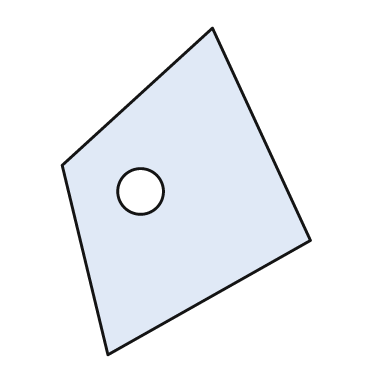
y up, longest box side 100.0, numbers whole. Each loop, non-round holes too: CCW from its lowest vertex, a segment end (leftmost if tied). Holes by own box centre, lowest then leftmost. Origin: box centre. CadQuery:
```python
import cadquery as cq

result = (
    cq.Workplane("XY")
    .moveTo(-24.0, -50.0)
    .lineTo(38.0, -15.0)
    .lineTo(8.0, 50.0)
    .lineTo(-38.0, 8.0)
    .close()
    .moveTo(-14.0, 0.0)
    .circle(7.0)
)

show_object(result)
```